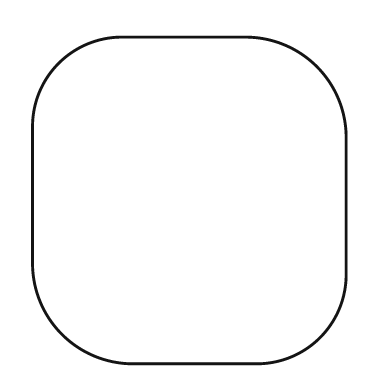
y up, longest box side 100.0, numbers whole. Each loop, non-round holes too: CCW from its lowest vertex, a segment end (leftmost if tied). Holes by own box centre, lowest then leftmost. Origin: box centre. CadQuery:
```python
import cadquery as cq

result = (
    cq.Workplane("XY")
    .moveTo(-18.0, -50.0)
    .lineTo(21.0, -50.0)
    .threePointArc((40.0, -42.0), (48.0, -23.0))
    .lineTo(48.0, 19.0)
    .threePointArc((39.0, 41.0), (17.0, 50.0))
    .lineTo(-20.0, 50.0)
    .threePointArc((-40.0, 42.0), (-48.0, 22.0))
    .lineTo(-48.0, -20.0)
    .threePointArc((-39.0, -41.0), (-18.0, -50.0))
    .close()
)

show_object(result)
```